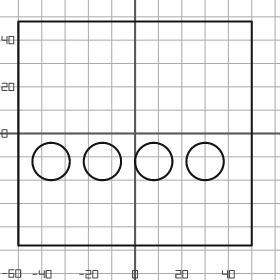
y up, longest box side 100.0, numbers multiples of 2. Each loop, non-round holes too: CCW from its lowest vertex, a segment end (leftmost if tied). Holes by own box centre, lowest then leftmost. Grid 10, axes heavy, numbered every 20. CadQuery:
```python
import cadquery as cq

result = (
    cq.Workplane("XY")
    .moveTo(-50.0, -48.0)
    .lineTo(50.0, -48.0)
    .lineTo(50.0, 48.0)
    .lineTo(-50.0, 48.0)
    .close()
    .moveTo(-36.0, -12.0)
    .circle(8.0)
    .moveTo(-14.0, -12.0)
    .circle(8.0)
    .moveTo(8.0, -12.0)
    .circle(8.0)
    .moveTo(30.0, -12.0)
    .circle(8.0)
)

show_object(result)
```